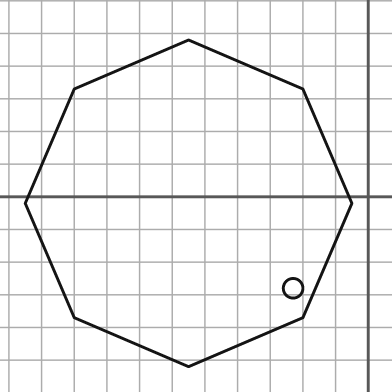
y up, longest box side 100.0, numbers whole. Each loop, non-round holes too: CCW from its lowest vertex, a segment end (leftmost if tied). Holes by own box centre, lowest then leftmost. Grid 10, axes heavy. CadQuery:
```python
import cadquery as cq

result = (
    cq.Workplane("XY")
    .moveTo(-55.0, -52.0)
    .lineTo(-20.0, -37.0)
    .lineTo(-5.0, -2.0)
    .lineTo(-20.0, 33.0)
    .lineTo(-55.0, 48.0)
    .lineTo(-90.0, 33.0)
    .lineTo(-105.0, -2.0)
    .lineTo(-90.0, -37.0)
    .close()
    .moveTo(-23.0, -28.0)
    .circle(3.0)
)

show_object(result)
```